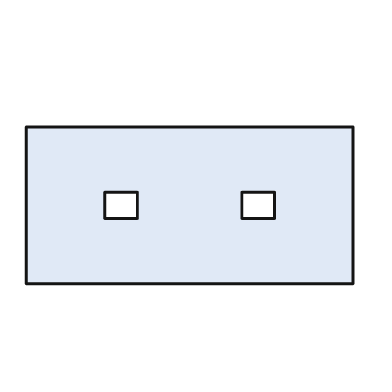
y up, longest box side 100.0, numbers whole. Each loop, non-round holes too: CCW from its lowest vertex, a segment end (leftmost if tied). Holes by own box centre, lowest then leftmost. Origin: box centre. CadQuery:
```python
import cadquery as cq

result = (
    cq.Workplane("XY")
    .moveTo(-50.0, -24.0)
    .lineTo(50.0, -24.0)
    .lineTo(50.0, 24.0)
    .lineTo(-50.0, 24.0)
    .close()
    .moveTo(-26.0, -4.0)
    .lineTo(-16.0, -4.0)
    .lineTo(-16.0, 4.0)
    .lineTo(-26.0, 4.0)
    .close()
    .moveTo(16.0, -4.0)
    .lineTo(26.0, -4.0)
    .lineTo(26.0, 4.0)
    .lineTo(16.0, 4.0)
    .close()
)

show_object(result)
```